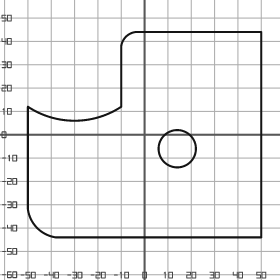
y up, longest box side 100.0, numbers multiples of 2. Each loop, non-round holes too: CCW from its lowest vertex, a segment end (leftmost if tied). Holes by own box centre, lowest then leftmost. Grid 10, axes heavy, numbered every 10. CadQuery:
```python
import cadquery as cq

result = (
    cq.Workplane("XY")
    .moveTo(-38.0, -44.0)
    .lineTo(50.0, -44.0)
    .lineTo(50.0, 44.0)
    .lineTo(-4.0, 44.0)
    .threePointArc((-8.0, 42.0), (-10.0, 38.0))
    .lineTo(-10.0, 12.0)
    .threePointArc((-30.0, 6.0), (-50.0, 12.0))
    .lineTo(-50.0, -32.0)
    .threePointArc((-46.0, -40.0), (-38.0, -44.0))
    .close()
    .moveTo(14.0, -6.0)
    .circle(8.0)
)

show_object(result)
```